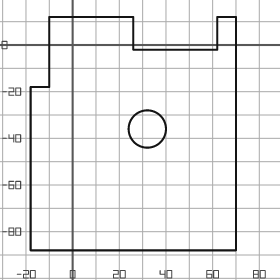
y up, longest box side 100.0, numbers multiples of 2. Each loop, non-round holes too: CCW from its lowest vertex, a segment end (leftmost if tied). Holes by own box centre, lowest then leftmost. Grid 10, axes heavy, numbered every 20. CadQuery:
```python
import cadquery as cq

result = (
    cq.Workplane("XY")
    .moveTo(-18.0, -88.0)
    .lineTo(70.0, -88.0)
    .lineTo(70.0, 12.0)
    .lineTo(62.0, 12.0)
    .lineTo(62.0, -2.0)
    .lineTo(26.0, -2.0)
    .lineTo(26.0, 12.0)
    .lineTo(-10.0, 12.0)
    .lineTo(-10.0, -18.0)
    .lineTo(-18.0, -18.0)
    .close()
    .moveTo(32.0, -36.0)
    .circle(8.0)
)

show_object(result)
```